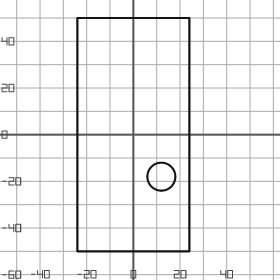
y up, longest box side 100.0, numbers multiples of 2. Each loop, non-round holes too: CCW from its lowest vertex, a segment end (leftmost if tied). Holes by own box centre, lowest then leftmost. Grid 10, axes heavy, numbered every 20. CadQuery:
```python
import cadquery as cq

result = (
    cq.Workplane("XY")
    .moveTo(-24.0, -50.0)
    .lineTo(24.0, -50.0)
    .lineTo(24.0, 50.0)
    .lineTo(-24.0, 50.0)
    .close()
    .moveTo(12.0, -18.0)
    .circle(6.0)
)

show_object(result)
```